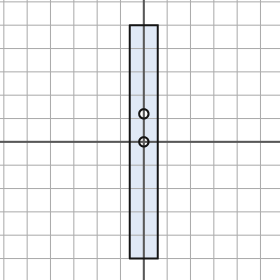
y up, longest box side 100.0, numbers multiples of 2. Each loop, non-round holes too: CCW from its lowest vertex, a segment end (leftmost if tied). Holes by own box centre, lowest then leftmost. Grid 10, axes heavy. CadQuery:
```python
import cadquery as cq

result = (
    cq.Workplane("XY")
    .moveTo(-6.0, -50.0)
    .lineTo(6.0, -50.0)
    .lineTo(6.0, 50.0)
    .lineTo(-6.0, 50.0)
    .close()
    .moveTo(0.0, 0.0)
    .circle(2.0)
    .moveTo(0.0, 12.0)
    .circle(2.0)
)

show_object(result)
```